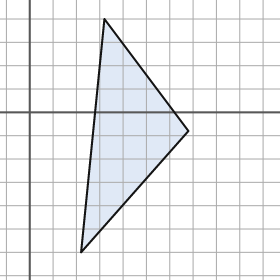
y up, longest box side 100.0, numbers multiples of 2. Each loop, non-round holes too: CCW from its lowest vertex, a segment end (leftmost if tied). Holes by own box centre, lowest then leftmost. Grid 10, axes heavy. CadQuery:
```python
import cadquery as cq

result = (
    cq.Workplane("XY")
    .moveTo(22.0, -60.0)
    .lineTo(68.0, -8.0)
    .lineTo(32.0, 40.0)
    .close()
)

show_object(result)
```